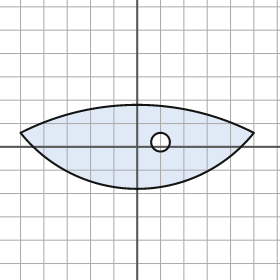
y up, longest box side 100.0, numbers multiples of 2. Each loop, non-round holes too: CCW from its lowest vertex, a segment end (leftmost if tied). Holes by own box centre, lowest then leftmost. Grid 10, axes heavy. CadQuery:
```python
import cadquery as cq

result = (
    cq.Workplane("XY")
    .moveTo(-50.0, 6.0)
    .threePointArc((0.0, -18.0), (50.0, 6.0))
    .threePointArc((0.0, 18.0), (-50.0, 6.0))
    .close()
    .moveTo(10.0, 2.0)
    .circle(4.0)
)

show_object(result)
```